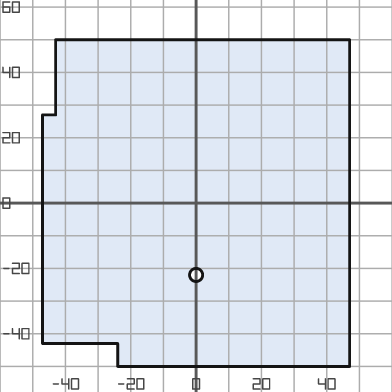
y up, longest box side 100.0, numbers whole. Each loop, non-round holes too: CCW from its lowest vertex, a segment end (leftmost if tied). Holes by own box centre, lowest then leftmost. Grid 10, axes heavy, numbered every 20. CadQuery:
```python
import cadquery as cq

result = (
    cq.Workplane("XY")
    .moveTo(-24.0, -50.0)
    .lineTo(47.0, -50.0)
    .lineTo(47.0, 50.0)
    .lineTo(-43.0, 50.0)
    .lineTo(-43.0, 27.0)
    .lineTo(-47.0, 27.0)
    .lineTo(-47.0, -43.0)
    .lineTo(-24.0, -43.0)
    .close()
    .moveTo(0.0, -22.0)
    .circle(2.0)
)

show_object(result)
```